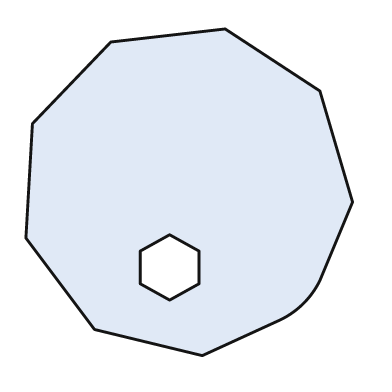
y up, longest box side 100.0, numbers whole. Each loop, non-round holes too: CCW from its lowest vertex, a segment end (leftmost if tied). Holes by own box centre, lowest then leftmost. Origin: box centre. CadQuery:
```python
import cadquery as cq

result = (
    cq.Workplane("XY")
    .moveTo(4.0, -50.0)
    .lineTo(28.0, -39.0)
    .threePointArc((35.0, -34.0), (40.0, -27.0))
    .lineTo(50.0, -3.0)
    .lineTo(40.0, 31.0)
    .lineTo(11.0, 50.0)
    .lineTo(-24.0, 46.0)
    .lineTo(-48.0, 21.0)
    .lineTo(-50.0, -14.0)
    .lineTo(-29.0, -42.0)
    .close()
    .moveTo(-6.0, -33.0)
    .lineTo(3.0, -28.0)
    .lineTo(3.0, -18.0)
    .lineTo(-6.0, -13.0)
    .lineTo(-15.0, -18.0)
    .lineTo(-15.0, -28.0)
    .close()
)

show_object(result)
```